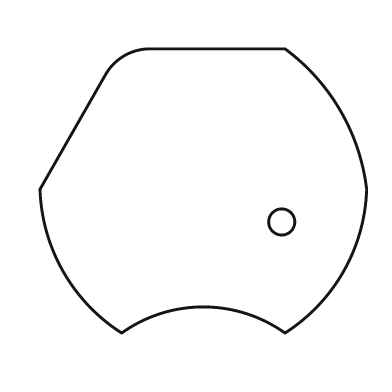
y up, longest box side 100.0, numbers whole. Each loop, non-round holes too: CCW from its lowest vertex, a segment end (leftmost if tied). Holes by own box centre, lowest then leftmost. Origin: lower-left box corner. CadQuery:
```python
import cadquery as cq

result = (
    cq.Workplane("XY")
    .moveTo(25.0, 0.0)
    .threePointArc((50.0, 8.0), (75.0, 0.0))
    .threePointArc((93.0, 19.0), (100.0, 44.0))
    .threePointArc((92.0, 68.0), (75.0, 87.0))
    .lineTo(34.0, 87.0)
    .threePointArc((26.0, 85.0), (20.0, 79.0))
    .lineTo(0.0, 44.0)
    .threePointArc((7.0, 19.0), (25.0, 0.0))
    .close()
    .moveTo(74.0, 34.0)
    .circle(4.0)
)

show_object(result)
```